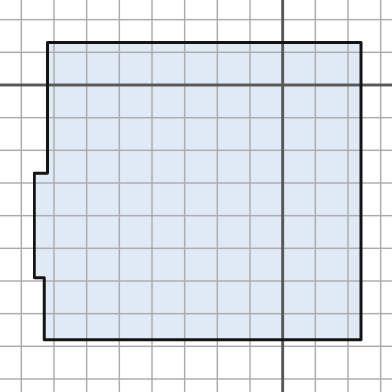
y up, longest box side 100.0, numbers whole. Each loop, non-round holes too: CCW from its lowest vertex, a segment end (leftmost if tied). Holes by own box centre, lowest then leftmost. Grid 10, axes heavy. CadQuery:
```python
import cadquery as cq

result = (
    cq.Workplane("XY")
    .moveTo(-73.0, -78.0)
    .lineTo(24.0, -78.0)
    .lineTo(24.0, 13.0)
    .lineTo(-72.0, 13.0)
    .lineTo(-72.0, -27.0)
    .lineTo(-76.0, -27.0)
    .lineTo(-76.0, -59.0)
    .lineTo(-73.0, -59.0)
    .close()
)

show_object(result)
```